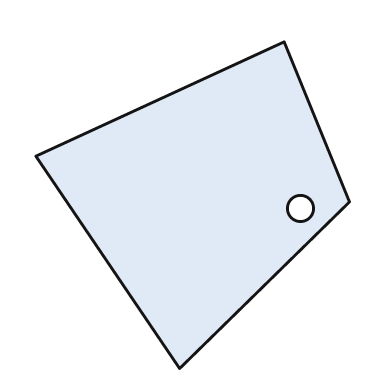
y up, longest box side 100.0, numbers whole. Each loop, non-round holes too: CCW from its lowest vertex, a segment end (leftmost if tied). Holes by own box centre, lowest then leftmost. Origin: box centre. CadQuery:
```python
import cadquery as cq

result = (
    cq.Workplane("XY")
    .moveTo(-4.0, -50.0)
    .lineTo(48.0, 1.0)
    .lineTo(28.0, 50.0)
    .lineTo(-48.0, 15.0)
    .close()
    .moveTo(33.0, -1.0)
    .circle(4.0)
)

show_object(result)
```